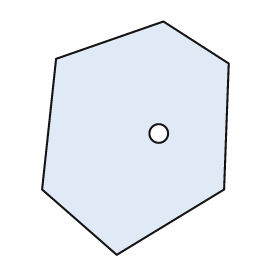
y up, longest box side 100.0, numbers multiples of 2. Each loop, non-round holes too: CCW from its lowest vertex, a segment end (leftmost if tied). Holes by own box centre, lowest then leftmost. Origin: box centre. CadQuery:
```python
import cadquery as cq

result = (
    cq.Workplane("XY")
    .moveTo(-8.0, -50.0)
    .lineTo(38.0, -22.0)
    .lineTo(40.0, 32.0)
    .lineTo(12.0, 50.0)
    .lineTo(-34.0, 34.0)
    .lineTo(-40.0, -22.0)
    .close()
    .moveTo(10.0, 2.0)
    .circle(4.0)
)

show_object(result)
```